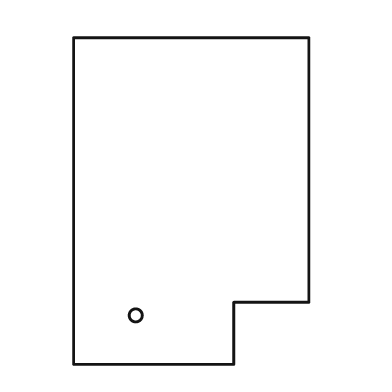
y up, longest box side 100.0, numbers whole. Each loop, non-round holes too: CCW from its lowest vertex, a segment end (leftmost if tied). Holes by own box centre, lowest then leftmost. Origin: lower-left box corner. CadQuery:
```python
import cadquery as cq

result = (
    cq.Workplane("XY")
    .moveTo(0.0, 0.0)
    .lineTo(49.0, 0.0)
    .lineTo(49.0, 19.0)
    .lineTo(72.0, 19.0)
    .lineTo(72.0, 100.0)
    .lineTo(0.0, 100.0)
    .close()
    .moveTo(19.0, 15.0)
    .circle(2.0)
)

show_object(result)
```